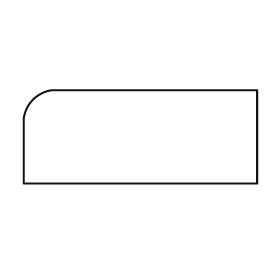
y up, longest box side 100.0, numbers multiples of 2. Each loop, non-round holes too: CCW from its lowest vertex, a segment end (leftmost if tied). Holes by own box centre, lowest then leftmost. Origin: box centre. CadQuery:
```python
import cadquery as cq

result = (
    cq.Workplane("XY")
    .moveTo(-50.0, -20.0)
    .lineTo(50.0, -20.0)
    .lineTo(50.0, 20.0)
    .lineTo(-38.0, 20.0)
    .threePointArc((-46.0, 16.0), (-50.0, 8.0))
    .close()
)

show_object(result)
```